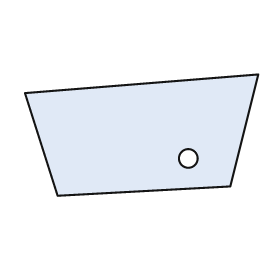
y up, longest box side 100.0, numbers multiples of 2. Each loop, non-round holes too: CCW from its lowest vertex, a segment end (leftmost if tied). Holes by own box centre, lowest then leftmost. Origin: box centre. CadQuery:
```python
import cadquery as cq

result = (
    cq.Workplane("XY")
    .moveTo(-36.0, -26.0)
    .lineTo(38.0, -22.0)
    .lineTo(50.0, 26.0)
    .lineTo(-50.0, 18.0)
    .close()
    .moveTo(20.0, -10.0)
    .circle(4.0)
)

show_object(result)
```